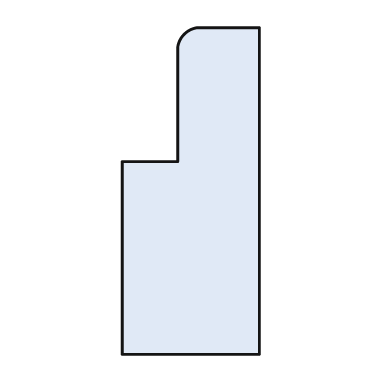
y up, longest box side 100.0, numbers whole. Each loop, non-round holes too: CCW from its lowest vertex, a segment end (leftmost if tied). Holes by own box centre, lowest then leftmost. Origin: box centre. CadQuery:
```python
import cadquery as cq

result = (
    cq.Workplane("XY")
    .moveTo(-21.0, -50.0)
    .lineTo(21.0, -50.0)
    .lineTo(21.0, 50.0)
    .lineTo(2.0, 50.0)
    .threePointArc((-2.0, 48.0), (-4.0, 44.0))
    .lineTo(-4.0, 9.0)
    .lineTo(-21.0, 9.0)
    .close()
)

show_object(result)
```